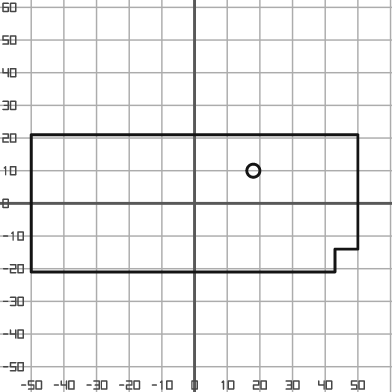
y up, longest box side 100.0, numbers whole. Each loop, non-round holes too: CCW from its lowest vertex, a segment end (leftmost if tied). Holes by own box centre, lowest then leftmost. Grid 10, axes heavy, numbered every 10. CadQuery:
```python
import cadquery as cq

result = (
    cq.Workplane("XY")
    .moveTo(-50.0, -21.0)
    .lineTo(43.0, -21.0)
    .lineTo(43.0, -14.0)
    .lineTo(50.0, -14.0)
    .lineTo(50.0, 21.0)
    .lineTo(-50.0, 21.0)
    .close()
    .moveTo(18.0, 10.0)
    .circle(2.0)
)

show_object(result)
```